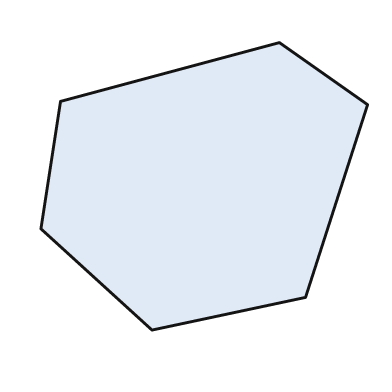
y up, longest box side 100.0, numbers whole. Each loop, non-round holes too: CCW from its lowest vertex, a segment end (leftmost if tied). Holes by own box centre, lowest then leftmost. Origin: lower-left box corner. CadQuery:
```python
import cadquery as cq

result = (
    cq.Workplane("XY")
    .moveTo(34.0, 0.0)
    .lineTo(81.0, 10.0)
    .lineTo(100.0, 69.0)
    .lineTo(73.0, 88.0)
    .lineTo(6.0, 70.0)
    .lineTo(0.0, 31.0)
    .close()
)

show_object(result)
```